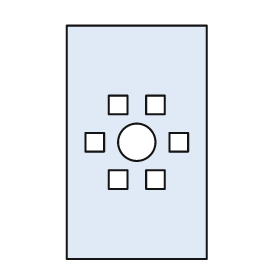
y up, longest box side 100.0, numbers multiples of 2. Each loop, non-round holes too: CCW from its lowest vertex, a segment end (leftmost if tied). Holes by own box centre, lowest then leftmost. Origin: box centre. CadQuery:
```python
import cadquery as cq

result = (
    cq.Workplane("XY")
    .moveTo(-30.0, -50.0)
    .lineTo(30.0, -50.0)
    .lineTo(30.0, 50.0)
    .lineTo(-30.0, 50.0)
    .close()
    .moveTo(-12.0, -20.0)
    .lineTo(-4.0, -20.0)
    .lineTo(-4.0, -12.0)
    .lineTo(-12.0, -12.0)
    .close()
    .moveTo(4.0, -20.0)
    .lineTo(12.0, -20.0)
    .lineTo(12.0, -12.0)
    .lineTo(4.0, -12.0)
    .close()
    .moveTo(-22.0, -4.0)
    .lineTo(-14.0, -4.0)
    .lineTo(-14.0, 4.0)
    .lineTo(-22.0, 4.0)
    .close()
    .moveTo(0.0, 0.0)
    .circle(8.0)
    .moveTo(14.0, -4.0)
    .lineTo(22.0, -4.0)
    .lineTo(22.0, 4.0)
    .lineTo(14.0, 4.0)
    .close()
    .moveTo(-12.0, 12.0)
    .lineTo(-4.0, 12.0)
    .lineTo(-4.0, 20.0)
    .lineTo(-12.0, 20.0)
    .close()
    .moveTo(4.0, 12.0)
    .lineTo(12.0, 12.0)
    .lineTo(12.0, 20.0)
    .lineTo(4.0, 20.0)
    .close()
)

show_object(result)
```